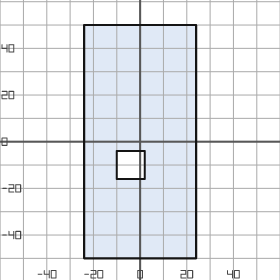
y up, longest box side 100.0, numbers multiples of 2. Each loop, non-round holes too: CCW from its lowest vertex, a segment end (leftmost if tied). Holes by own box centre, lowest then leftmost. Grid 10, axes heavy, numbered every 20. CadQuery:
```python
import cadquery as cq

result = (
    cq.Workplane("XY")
    .moveTo(-24.0, -50.0)
    .lineTo(24.0, -50.0)
    .lineTo(24.0, 50.0)
    .lineTo(-24.0, 50.0)
    .close()
    .moveTo(-10.0, -16.0)
    .lineTo(2.0, -16.0)
    .lineTo(2.0, -4.0)
    .lineTo(-10.0, -4.0)
    .close()
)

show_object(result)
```